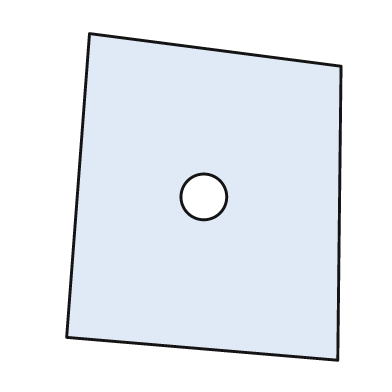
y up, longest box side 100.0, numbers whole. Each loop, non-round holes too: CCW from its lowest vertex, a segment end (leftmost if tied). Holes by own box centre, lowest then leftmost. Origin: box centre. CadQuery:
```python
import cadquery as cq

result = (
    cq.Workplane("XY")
    .moveTo(41.0, -50.0)
    .lineTo(42.0, 40.0)
    .lineTo(-35.0, 50.0)
    .lineTo(-42.0, -43.0)
    .close()
    .moveTo(0.0, 0.0)
    .circle(7.0)
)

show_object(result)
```